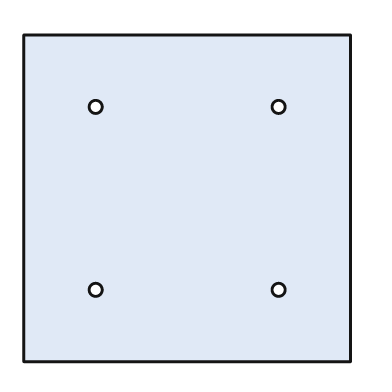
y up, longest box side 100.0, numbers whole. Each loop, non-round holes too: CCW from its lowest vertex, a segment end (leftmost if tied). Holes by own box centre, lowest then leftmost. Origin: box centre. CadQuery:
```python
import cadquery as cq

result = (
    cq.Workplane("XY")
    .moveTo(-50.0, -50.0)
    .lineTo(50.0, -50.0)
    .lineTo(50.0, 50.0)
    .lineTo(-50.0, 50.0)
    .close()
    .moveTo(-28.0, -28.0)
    .circle(2.0)
    .moveTo(28.0, -28.0)
    .circle(2.0)
    .moveTo(-28.0, 28.0)
    .circle(2.0)
    .moveTo(28.0, 28.0)
    .circle(2.0)
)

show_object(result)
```